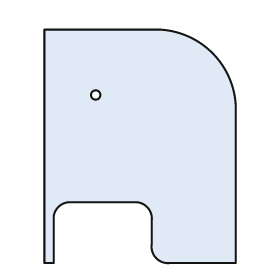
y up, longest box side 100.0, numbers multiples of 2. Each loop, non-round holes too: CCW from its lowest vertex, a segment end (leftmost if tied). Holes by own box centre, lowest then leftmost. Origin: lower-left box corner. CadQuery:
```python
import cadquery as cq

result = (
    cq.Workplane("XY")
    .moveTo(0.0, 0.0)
    .lineTo(4.0, 0.0)
    .lineTo(4.0, 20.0)
    .threePointArc((6.0, 24.0), (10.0, 26.0))
    .lineTo(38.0, 26.0)
    .threePointArc((44.0, 24.0), (46.0, 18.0))
    .lineTo(46.0, 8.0)
    .threePointArc((48.0, 2.0), (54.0, 0.0))
    .lineTo(82.0, 0.0)
    .lineTo(82.0, 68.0)
    .threePointArc((72.0, 90.0), (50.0, 100.0))
    .lineTo(0.0, 100.0)
    .close()
    .moveTo(22.0, 72.0)
    .circle(2.0)
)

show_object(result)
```